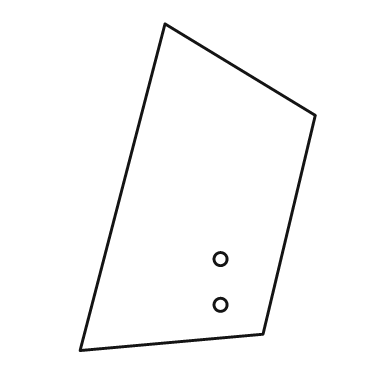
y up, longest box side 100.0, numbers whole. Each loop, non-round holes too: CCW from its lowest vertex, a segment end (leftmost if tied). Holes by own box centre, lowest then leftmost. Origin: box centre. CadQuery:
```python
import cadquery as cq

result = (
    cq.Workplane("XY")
    .moveTo(-36.0, -50.0)
    .lineTo(20.0, -45.0)
    .lineTo(36.0, 22.0)
    .lineTo(-10.0, 50.0)
    .close()
    .moveTo(7.0, -36.0)
    .circle(2.0)
    .moveTo(7.0, -22.0)
    .circle(2.0)
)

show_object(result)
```